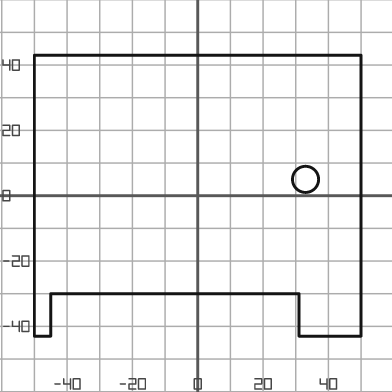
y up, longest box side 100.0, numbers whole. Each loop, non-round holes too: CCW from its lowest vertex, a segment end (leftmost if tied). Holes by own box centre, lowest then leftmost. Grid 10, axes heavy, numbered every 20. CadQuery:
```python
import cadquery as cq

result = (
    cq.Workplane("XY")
    .moveTo(-50.0, -43.0)
    .lineTo(-45.0, -43.0)
    .lineTo(-45.0, -30.0)
    .lineTo(31.0, -30.0)
    .lineTo(31.0, -43.0)
    .lineTo(50.0, -43.0)
    .lineTo(50.0, 43.0)
    .lineTo(-50.0, 43.0)
    .close()
    .moveTo(33.0, 5.0)
    .circle(4.0)
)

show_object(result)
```